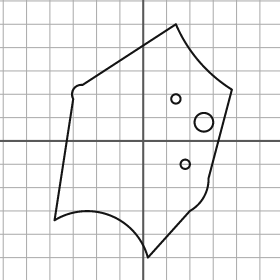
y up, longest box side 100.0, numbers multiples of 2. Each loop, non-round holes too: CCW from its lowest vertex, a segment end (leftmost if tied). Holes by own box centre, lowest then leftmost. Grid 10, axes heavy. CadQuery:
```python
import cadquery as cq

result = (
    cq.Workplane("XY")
    .moveTo(2.0, -50.0)
    .lineTo(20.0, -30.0)
    .threePointArc((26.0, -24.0), (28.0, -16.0))
    .lineTo(38.0, 22.0)
    .threePointArc((24.0, 34.0), (14.0, 50.0))
    .lineTo(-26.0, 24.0)
    .threePointArc((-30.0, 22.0), (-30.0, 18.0))
    .lineTo(-38.0, -34.0)
    .threePointArc((-14.0, -32.0), (2.0, -50.0))
    .close()
    .moveTo(18.0, -10.0)
    .circle(2.0)
    .moveTo(26.0, 8.0)
    .circle(4.0)
    .moveTo(14.0, 18.0)
    .circle(2.0)
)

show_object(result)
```